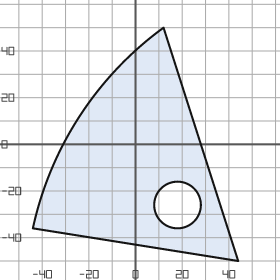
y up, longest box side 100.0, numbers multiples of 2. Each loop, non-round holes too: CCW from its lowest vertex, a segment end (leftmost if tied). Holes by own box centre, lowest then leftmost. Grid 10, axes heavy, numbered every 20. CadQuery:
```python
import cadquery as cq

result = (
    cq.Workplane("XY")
    .moveTo(44.0, -50.0)
    .lineTo(12.0, 50.0)
    .threePointArc((-24.0, 12.0), (-44.0, -36.0))
    .close()
    .moveTo(18.0, -26.0)
    .circle(10.0)
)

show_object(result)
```